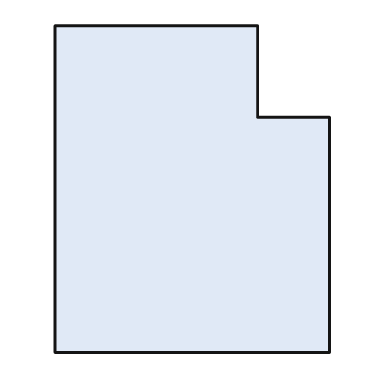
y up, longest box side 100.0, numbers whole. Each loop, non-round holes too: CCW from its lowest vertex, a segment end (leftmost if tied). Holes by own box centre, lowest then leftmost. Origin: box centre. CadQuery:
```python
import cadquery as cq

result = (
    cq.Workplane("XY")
    .moveTo(-42.0, -50.0)
    .lineTo(42.0, -50.0)
    .lineTo(42.0, 22.0)
    .lineTo(20.0, 22.0)
    .lineTo(20.0, 50.0)
    .lineTo(-42.0, 50.0)
    .close()
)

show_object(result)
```